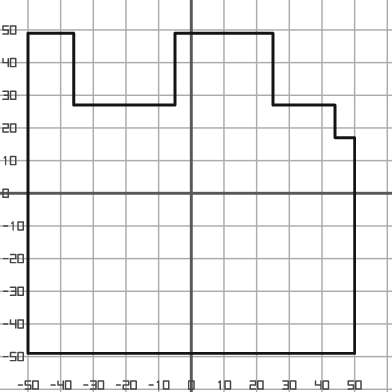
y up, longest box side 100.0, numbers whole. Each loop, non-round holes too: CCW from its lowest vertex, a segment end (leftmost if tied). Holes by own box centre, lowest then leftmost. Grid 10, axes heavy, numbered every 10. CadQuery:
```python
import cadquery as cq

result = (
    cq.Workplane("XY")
    .moveTo(-50.0, -49.0)
    .lineTo(50.0, -49.0)
    .lineTo(50.0, 17.0)
    .lineTo(44.0, 17.0)
    .lineTo(44.0, 27.0)
    .lineTo(25.0, 27.0)
    .lineTo(25.0, 49.0)
    .lineTo(-5.0, 49.0)
    .lineTo(-5.0, 27.0)
    .lineTo(-36.0, 27.0)
    .lineTo(-36.0, 49.0)
    .lineTo(-50.0, 49.0)
    .close()
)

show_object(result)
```